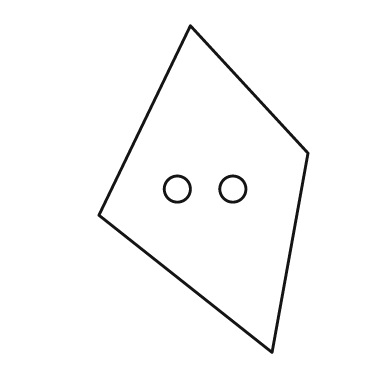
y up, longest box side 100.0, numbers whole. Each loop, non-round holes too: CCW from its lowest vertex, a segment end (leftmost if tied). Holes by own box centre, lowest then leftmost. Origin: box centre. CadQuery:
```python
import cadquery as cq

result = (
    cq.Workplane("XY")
    .moveTo(21.0, -50.0)
    .lineTo(32.0, 11.0)
    .lineTo(-4.0, 50.0)
    .lineTo(-32.0, -8.0)
    .close()
    .moveTo(-8.0, 0.0)
    .circle(4.0)
    .moveTo(9.0, 0.0)
    .circle(4.0)
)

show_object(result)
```